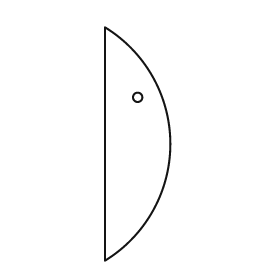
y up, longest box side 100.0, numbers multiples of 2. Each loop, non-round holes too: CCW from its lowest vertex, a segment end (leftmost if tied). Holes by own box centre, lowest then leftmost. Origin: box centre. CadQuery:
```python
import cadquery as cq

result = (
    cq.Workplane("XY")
    .moveTo(-14.0, -50.0)
    .threePointArc((14.0, 0.0), (-14.0, 50.0))
    .close()
    .moveTo(0.0, 20.0)
    .circle(2.0)
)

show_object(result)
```